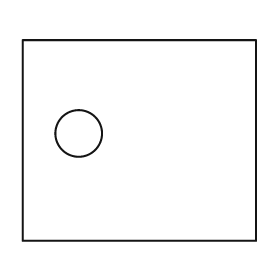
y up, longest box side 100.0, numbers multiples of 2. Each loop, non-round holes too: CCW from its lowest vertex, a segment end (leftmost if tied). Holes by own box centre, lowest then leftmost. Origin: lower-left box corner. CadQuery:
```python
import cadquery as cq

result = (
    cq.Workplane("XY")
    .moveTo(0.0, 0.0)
    .lineTo(100.0, 0.0)
    .lineTo(100.0, 86.0)
    .lineTo(0.0, 86.0)
    .close()
    .moveTo(24.0, 46.0)
    .circle(10.0)
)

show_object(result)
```